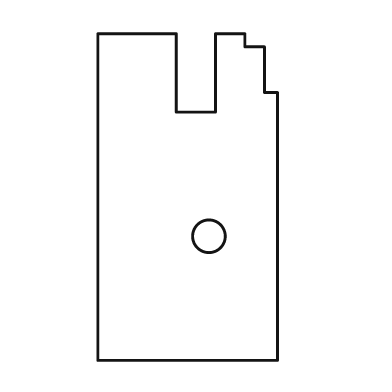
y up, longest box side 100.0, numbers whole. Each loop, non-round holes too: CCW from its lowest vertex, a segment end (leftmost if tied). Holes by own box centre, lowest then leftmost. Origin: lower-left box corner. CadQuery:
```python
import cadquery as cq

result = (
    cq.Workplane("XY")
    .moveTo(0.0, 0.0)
    .lineTo(55.0, 0.0)
    .lineTo(55.0, 82.0)
    .lineTo(51.0, 82.0)
    .lineTo(51.0, 96.0)
    .lineTo(45.0, 96.0)
    .lineTo(45.0, 100.0)
    .lineTo(36.0, 100.0)
    .lineTo(36.0, 76.0)
    .lineTo(24.0, 76.0)
    .lineTo(24.0, 100.0)
    .lineTo(0.0, 100.0)
    .close()
    .moveTo(34.0, 38.0)
    .circle(5.0)
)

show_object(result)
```